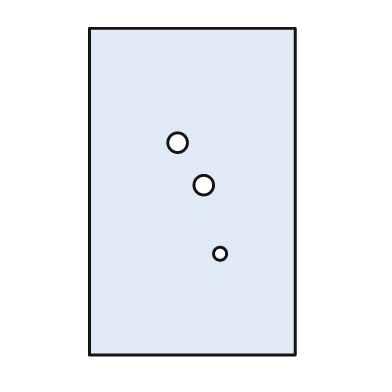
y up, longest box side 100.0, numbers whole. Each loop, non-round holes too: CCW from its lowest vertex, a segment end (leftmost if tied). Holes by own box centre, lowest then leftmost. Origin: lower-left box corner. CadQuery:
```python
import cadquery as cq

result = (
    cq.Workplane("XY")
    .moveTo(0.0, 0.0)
    .lineTo(63.0, 0.0)
    .lineTo(63.0, 100.0)
    .lineTo(0.0, 100.0)
    .close()
    .moveTo(40.0, 31.0)
    .circle(2.0)
    .moveTo(35.0, 52.0)
    .circle(3.0)
    .moveTo(27.0, 65.0)
    .circle(3.0)
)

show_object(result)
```